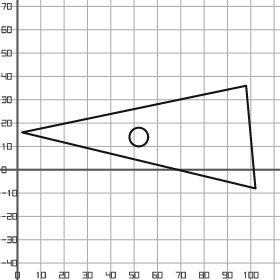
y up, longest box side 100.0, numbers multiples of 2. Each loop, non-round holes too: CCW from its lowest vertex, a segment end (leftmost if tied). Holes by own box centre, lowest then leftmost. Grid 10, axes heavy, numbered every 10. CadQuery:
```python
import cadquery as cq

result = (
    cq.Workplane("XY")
    .moveTo(102.0, -8.0)
    .lineTo(98.0, 36.0)
    .lineTo(2.0, 16.0)
    .close()
    .moveTo(52.0, 14.0)
    .circle(4.0)
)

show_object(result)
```